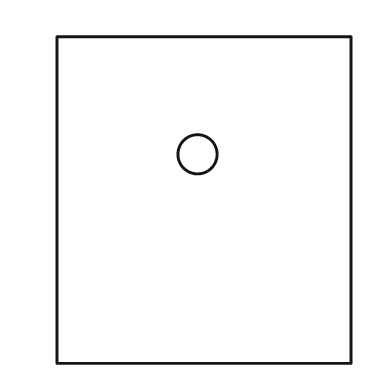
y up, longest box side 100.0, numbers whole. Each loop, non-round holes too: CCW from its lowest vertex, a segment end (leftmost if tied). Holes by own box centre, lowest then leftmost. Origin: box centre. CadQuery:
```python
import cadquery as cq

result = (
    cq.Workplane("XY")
    .moveTo(-45.0, -50.0)
    .lineTo(45.0, -50.0)
    .lineTo(45.0, 50.0)
    .lineTo(-45.0, 50.0)
    .close()
    .moveTo(-2.0, 14.0)
    .circle(6.0)
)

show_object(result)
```